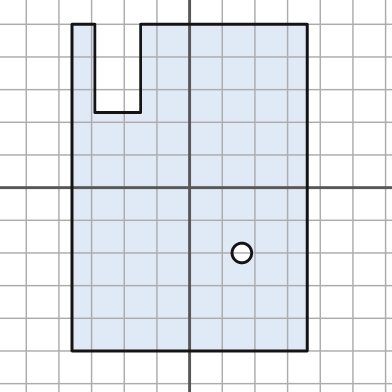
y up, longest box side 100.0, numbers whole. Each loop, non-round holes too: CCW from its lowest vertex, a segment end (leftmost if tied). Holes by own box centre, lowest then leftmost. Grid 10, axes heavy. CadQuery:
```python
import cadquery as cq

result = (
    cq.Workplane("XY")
    .moveTo(-36.0, -50.0)
    .lineTo(36.0, -50.0)
    .lineTo(36.0, 50.0)
    .lineTo(-15.0, 50.0)
    .lineTo(-15.0, 23.0)
    .lineTo(-29.0, 23.0)
    .lineTo(-29.0, 50.0)
    .lineTo(-36.0, 50.0)
    .close()
    .moveTo(16.0, -20.0)
    .circle(3.0)
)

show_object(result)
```